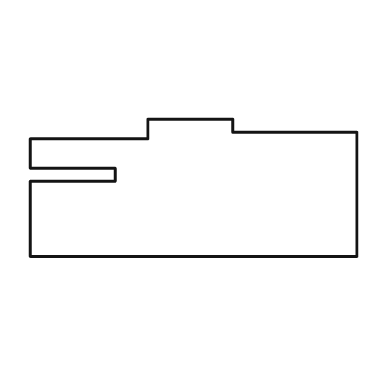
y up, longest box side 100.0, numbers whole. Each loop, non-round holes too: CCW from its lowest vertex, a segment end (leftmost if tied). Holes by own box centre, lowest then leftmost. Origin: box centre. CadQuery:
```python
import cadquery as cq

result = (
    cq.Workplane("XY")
    .moveTo(-50.0, -21.0)
    .lineTo(50.0, -21.0)
    .lineTo(50.0, 17.0)
    .lineTo(12.0, 17.0)
    .lineTo(12.0, 21.0)
    .lineTo(-14.0, 21.0)
    .lineTo(-14.0, 15.0)
    .lineTo(-50.0, 15.0)
    .lineTo(-50.0, 6.0)
    .lineTo(-24.0, 6.0)
    .lineTo(-24.0, 2.0)
    .lineTo(-50.0, 2.0)
    .close()
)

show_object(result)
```